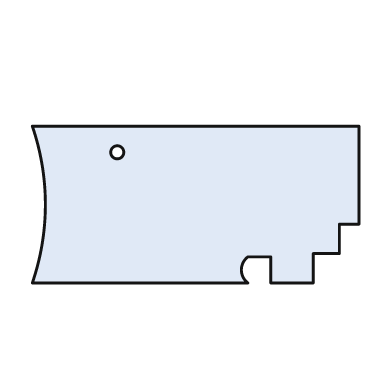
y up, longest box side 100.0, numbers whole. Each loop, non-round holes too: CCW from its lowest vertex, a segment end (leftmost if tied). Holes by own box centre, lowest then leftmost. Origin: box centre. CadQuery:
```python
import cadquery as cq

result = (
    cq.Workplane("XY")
    .moveTo(-50.0, -24.0)
    .lineTo(16.0, -24.0)
    .threePointArc((14.0, -20.0), (16.0, -16.0))
    .lineTo(23.0, -16.0)
    .lineTo(23.0, -24.0)
    .lineTo(36.0, -24.0)
    .lineTo(36.0, -15.0)
    .lineTo(44.0, -15.0)
    .lineTo(44.0, -6.0)
    .lineTo(50.0, -6.0)
    .lineTo(50.0, 24.0)
    .lineTo(-50.0, 24.0)
    .threePointArc((-46.0, 0.0), (-50.0, -24.0))
    .close()
    .moveTo(-24.0, 16.0)
    .circle(2.0)
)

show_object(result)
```